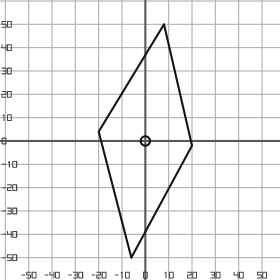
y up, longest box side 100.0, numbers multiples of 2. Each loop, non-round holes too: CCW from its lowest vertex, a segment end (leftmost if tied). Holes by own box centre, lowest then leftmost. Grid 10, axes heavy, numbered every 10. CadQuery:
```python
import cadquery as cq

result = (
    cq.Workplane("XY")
    .moveTo(-6.0, -50.0)
    .lineTo(20.0, -2.0)
    .lineTo(8.0, 50.0)
    .lineTo(-20.0, 4.0)
    .close()
    .moveTo(0.0, 0.0)
    .circle(2.0)
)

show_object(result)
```